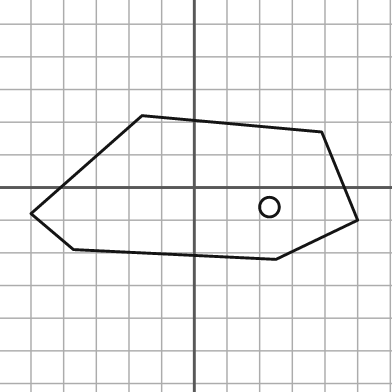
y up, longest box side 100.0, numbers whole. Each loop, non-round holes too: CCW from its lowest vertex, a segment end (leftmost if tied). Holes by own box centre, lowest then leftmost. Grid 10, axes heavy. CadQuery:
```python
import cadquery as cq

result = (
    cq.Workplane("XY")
    .moveTo(25.0, -22.0)
    .lineTo(50.0, -10.0)
    .lineTo(39.0, 17.0)
    .lineTo(-16.0, 22.0)
    .lineTo(-50.0, -8.0)
    .lineTo(-37.0, -19.0)
    .close()
    .moveTo(23.0, -6.0)
    .circle(3.0)
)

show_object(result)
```